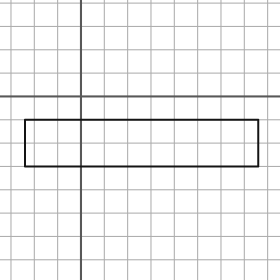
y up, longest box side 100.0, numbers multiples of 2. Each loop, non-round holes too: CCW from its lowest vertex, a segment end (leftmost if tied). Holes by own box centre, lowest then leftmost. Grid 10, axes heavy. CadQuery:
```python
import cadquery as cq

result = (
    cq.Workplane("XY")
    .moveTo(-24.0, -30.0)
    .lineTo(76.0, -30.0)
    .lineTo(76.0, -10.0)
    .lineTo(-24.0, -10.0)
    .close()
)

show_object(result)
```